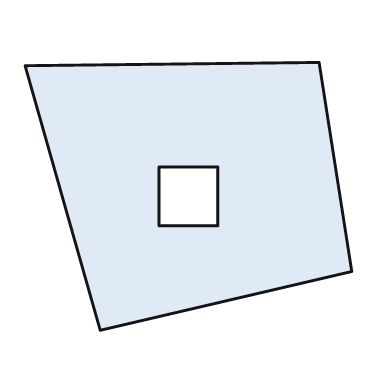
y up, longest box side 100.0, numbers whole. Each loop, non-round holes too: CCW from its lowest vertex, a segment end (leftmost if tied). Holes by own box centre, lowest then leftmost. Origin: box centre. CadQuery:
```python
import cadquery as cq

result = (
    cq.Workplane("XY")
    .moveTo(-27.0, -41.0)
    .lineTo(50.0, -23.0)
    .lineTo(40.0, 41.0)
    .lineTo(-50.0, 40.0)
    .close()
    .moveTo(-9.0, -9.0)
    .lineTo(9.0, -9.0)
    .lineTo(9.0, 9.0)
    .lineTo(-9.0, 9.0)
    .close()
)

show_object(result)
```